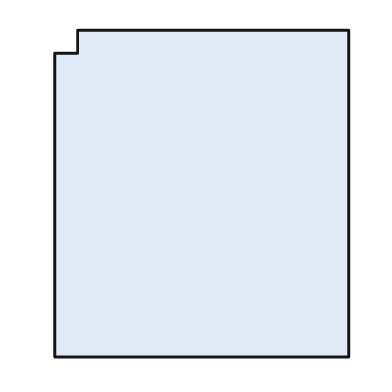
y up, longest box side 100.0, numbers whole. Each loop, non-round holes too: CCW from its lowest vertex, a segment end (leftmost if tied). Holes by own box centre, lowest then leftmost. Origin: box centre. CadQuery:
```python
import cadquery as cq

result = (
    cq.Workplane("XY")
    .moveTo(-45.0, -50.0)
    .lineTo(45.0, -50.0)
    .lineTo(45.0, 50.0)
    .lineTo(-38.0, 50.0)
    .lineTo(-38.0, 43.0)
    .lineTo(-45.0, 43.0)
    .close()
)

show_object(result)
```